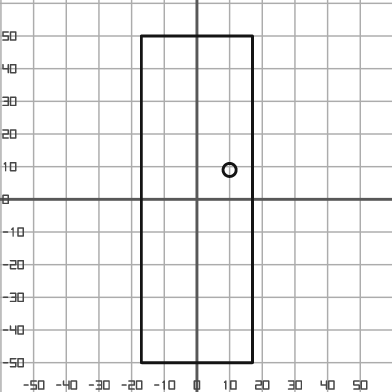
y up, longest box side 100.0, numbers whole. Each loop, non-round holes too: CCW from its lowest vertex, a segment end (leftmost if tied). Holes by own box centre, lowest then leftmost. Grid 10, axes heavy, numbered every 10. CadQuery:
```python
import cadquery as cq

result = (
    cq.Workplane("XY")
    .moveTo(-17.0, -50.0)
    .lineTo(17.0, -50.0)
    .lineTo(17.0, 50.0)
    .lineTo(-17.0, 50.0)
    .close()
    .moveTo(10.0, 9.0)
    .circle(2.0)
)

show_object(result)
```